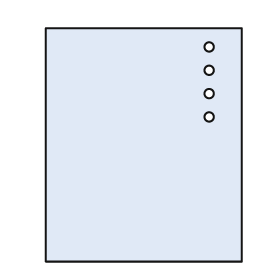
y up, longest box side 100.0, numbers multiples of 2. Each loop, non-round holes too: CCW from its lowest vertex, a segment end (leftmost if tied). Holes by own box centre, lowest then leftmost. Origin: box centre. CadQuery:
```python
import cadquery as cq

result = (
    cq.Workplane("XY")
    .moveTo(-42.0, -50.0)
    .lineTo(42.0, -50.0)
    .lineTo(42.0, 50.0)
    .lineTo(-42.0, 50.0)
    .close()
    .moveTo(28.0, 12.0)
    .circle(2.0)
    .moveTo(28.0, 22.0)
    .circle(2.0)
    .moveTo(28.0, 32.0)
    .circle(2.0)
    .moveTo(28.0, 42.0)
    .circle(2.0)
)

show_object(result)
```